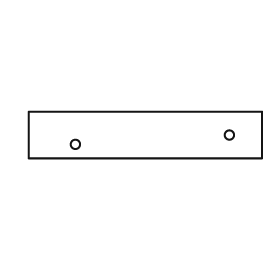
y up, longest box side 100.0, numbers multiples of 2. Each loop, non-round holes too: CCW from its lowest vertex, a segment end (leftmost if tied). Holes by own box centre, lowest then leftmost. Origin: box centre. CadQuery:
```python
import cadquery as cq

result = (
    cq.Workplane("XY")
    .moveTo(-50.0, -10.0)
    .lineTo(50.0, -10.0)
    .lineTo(50.0, 10.0)
    .lineTo(-50.0, 10.0)
    .close()
    .moveTo(-30.0, -4.0)
    .circle(2.0)
    .moveTo(36.0, 0.0)
    .circle(2.0)
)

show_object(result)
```